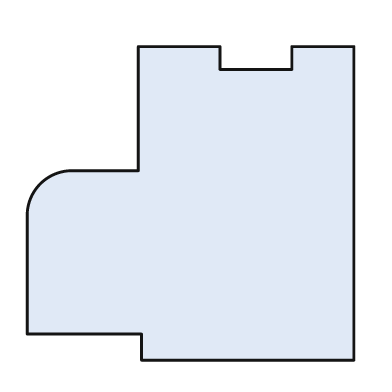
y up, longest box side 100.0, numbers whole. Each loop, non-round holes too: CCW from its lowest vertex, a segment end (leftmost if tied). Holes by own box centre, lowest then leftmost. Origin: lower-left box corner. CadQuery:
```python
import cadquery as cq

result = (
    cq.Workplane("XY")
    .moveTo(35.0, 0.0)
    .lineTo(100.0, 0.0)
    .lineTo(100.0, 96.0)
    .lineTo(81.0, 96.0)
    .lineTo(81.0, 89.0)
    .lineTo(59.0, 89.0)
    .lineTo(59.0, 96.0)
    .lineTo(34.0, 96.0)
    .lineTo(34.0, 58.0)
    .lineTo(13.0, 58.0)
    .threePointArc((4.0, 54.0), (0.0, 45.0))
    .lineTo(0.0, 8.0)
    .lineTo(35.0, 8.0)
    .close()
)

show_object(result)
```